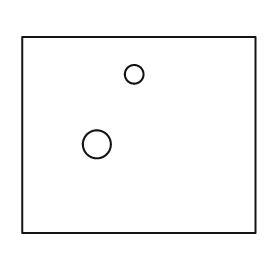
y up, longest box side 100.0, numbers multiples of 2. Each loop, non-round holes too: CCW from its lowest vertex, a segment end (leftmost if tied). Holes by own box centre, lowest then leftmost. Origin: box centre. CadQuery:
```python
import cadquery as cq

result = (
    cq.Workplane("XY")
    .moveTo(-50.0, -42.0)
    .lineTo(50.0, -42.0)
    .lineTo(50.0, 42.0)
    .lineTo(-50.0, 42.0)
    .close()
    .moveTo(-18.0, -4.0)
    .circle(6.0)
    .moveTo(-2.0, 26.0)
    .circle(4.0)
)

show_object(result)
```